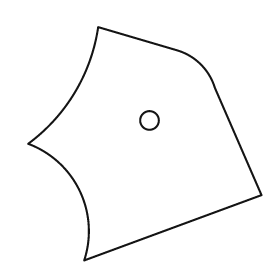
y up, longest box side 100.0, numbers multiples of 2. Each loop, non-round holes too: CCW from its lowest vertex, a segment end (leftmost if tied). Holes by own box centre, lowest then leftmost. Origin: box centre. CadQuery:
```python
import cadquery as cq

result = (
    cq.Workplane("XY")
    .moveTo(-26.0, -50.0)
    .lineTo(50.0, -22.0)
    .lineTo(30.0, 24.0)
    .threePointArc((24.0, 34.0), (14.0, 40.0))
    .lineTo(-20.0, 50.0)
    .threePointArc((-30.0, 22.0), (-50.0, 0.0))
    .threePointArc((-28.0, -20.0), (-26.0, -50.0))
    .close()
    .moveTo(2.0, 10.0)
    .circle(4.0)
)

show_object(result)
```